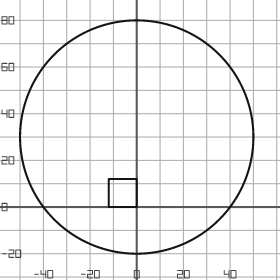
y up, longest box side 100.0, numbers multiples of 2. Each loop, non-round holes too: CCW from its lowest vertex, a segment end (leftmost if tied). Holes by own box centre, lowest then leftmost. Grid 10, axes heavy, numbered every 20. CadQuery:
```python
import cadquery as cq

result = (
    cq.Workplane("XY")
    .moveTo(0.0, 30.0)
    .circle(50.0)
    .moveTo(-12.0, 0.0)
    .lineTo(0.0, 0.0)
    .lineTo(0.0, 12.0)
    .lineTo(-12.0, 12.0)
    .close()
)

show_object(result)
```